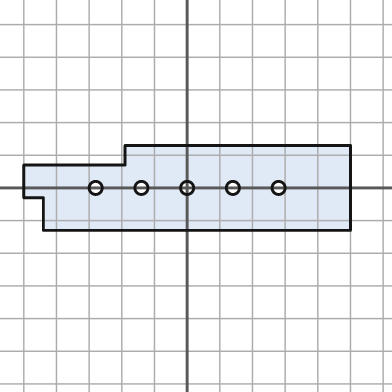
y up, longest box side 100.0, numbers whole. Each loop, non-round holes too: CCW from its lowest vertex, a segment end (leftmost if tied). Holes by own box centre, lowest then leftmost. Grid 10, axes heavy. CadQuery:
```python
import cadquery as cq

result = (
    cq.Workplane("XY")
    .moveTo(-44.0, -13.0)
    .lineTo(50.0, -13.0)
    .lineTo(50.0, 13.0)
    .lineTo(-19.0, 13.0)
    .lineTo(-19.0, 7.0)
    .lineTo(-50.0, 7.0)
    .lineTo(-50.0, -3.0)
    .lineTo(-44.0, -3.0)
    .close()
    .moveTo(-28.0, 0.0)
    .circle(2.0)
    .moveTo(-14.0, 0.0)
    .circle(2.0)
    .moveTo(0.0, 0.0)
    .circle(2.0)
    .moveTo(14.0, 0.0)
    .circle(2.0)
    .moveTo(28.0, 0.0)
    .circle(2.0)
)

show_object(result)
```